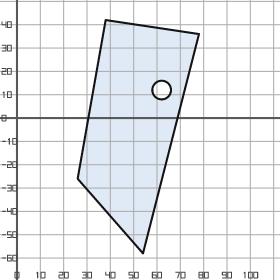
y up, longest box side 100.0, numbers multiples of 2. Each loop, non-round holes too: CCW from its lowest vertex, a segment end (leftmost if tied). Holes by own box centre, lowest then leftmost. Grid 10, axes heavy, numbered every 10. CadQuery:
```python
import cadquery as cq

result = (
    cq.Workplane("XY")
    .moveTo(54.0, -58.0)
    .lineTo(78.0, 36.0)
    .lineTo(38.0, 42.0)
    .lineTo(26.0, -26.0)
    .close()
    .moveTo(62.0, 12.0)
    .circle(4.0)
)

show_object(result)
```